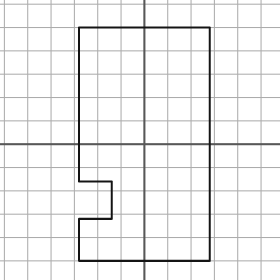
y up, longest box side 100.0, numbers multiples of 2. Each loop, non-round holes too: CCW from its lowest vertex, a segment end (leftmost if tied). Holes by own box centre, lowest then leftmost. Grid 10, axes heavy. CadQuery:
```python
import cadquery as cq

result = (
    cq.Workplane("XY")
    .moveTo(-28.0, -50.0)
    .lineTo(28.0, -50.0)
    .lineTo(28.0, 50.0)
    .lineTo(-28.0, 50.0)
    .lineTo(-28.0, -16.0)
    .lineTo(-14.0, -16.0)
    .lineTo(-14.0, -32.0)
    .lineTo(-28.0, -32.0)
    .close()
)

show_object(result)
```